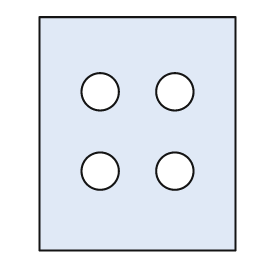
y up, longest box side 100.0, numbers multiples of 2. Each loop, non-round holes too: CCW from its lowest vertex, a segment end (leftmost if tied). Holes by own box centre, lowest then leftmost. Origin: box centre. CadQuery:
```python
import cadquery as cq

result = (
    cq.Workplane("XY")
    .moveTo(-42.0, -50.0)
    .lineTo(42.0, -50.0)
    .lineTo(42.0, 50.0)
    .lineTo(-42.0, 50.0)
    .close()
    .moveTo(-16.0, -16.0)
    .circle(8.0)
    .moveTo(16.0, -16.0)
    .circle(8.0)
    .moveTo(-16.0, 18.0)
    .circle(8.0)
    .moveTo(16.0, 18.0)
    .circle(8.0)
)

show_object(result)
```